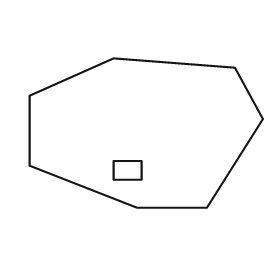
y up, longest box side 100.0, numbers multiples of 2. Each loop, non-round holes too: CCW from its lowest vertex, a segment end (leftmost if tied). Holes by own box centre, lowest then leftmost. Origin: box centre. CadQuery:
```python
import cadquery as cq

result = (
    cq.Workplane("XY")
    .moveTo(-4.0, -32.0)
    .lineTo(26.0, -32.0)
    .lineTo(50.0, 6.0)
    .lineTo(38.0, 28.0)
    .lineTo(-14.0, 32.0)
    .lineTo(-50.0, 16.0)
    .lineTo(-50.0, -14.0)
    .close()
    .moveTo(-14.0, -20.0)
    .lineTo(-2.0, -20.0)
    .lineTo(-2.0, -12.0)
    .lineTo(-14.0, -12.0)
    .close()
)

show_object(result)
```